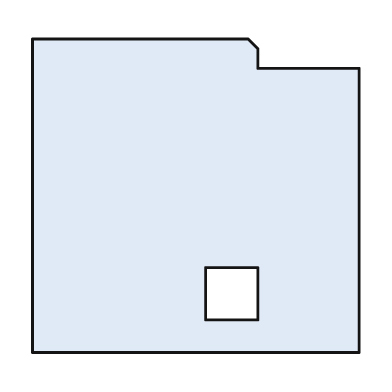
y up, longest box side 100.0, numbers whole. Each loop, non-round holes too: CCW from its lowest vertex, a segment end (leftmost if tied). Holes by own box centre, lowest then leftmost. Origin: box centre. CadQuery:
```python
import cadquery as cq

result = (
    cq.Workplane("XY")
    .moveTo(-50.0, -48.0)
    .lineTo(50.0, -48.0)
    .lineTo(50.0, 39.0)
    .lineTo(19.0, 39.0)
    .lineTo(19.0, 45.0)
    .lineTo(16.0, 48.0)
    .lineTo(-50.0, 48.0)
    .close()
    .moveTo(3.0, -38.0)
    .lineTo(19.0, -38.0)
    .lineTo(19.0, -22.0)
    .lineTo(3.0, -22.0)
    .close()
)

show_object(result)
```